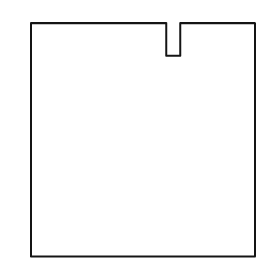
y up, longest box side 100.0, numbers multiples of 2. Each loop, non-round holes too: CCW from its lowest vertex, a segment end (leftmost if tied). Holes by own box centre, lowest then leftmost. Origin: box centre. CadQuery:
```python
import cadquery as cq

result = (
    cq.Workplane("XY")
    .moveTo(-48.0, -50.0)
    .lineTo(48.0, -50.0)
    .lineTo(48.0, 50.0)
    .lineTo(16.0, 50.0)
    .lineTo(16.0, 36.0)
    .lineTo(10.0, 36.0)
    .lineTo(10.0, 50.0)
    .lineTo(-48.0, 50.0)
    .close()
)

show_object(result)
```